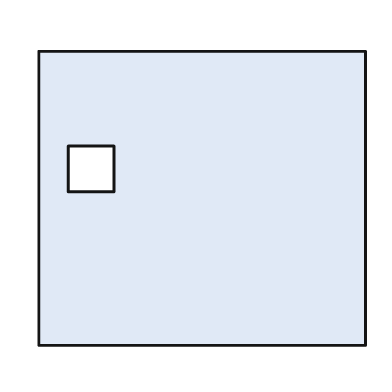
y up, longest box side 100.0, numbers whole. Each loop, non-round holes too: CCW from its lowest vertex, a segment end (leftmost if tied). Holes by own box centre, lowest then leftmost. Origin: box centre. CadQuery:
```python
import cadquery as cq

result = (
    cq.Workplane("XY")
    .moveTo(-50.0, -45.0)
    .lineTo(50.0, -45.0)
    .lineTo(50.0, 45.0)
    .lineTo(-50.0, 45.0)
    .close()
    .moveTo(-41.0, 2.0)
    .lineTo(-27.0, 2.0)
    .lineTo(-27.0, 16.0)
    .lineTo(-41.0, 16.0)
    .close()
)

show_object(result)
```